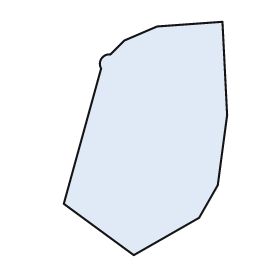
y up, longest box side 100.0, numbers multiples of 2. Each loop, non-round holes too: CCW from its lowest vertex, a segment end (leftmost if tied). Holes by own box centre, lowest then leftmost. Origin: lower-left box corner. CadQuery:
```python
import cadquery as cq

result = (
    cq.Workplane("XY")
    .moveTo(30.0, 0.0)
    .lineTo(58.0, 16.0)
    .lineTo(66.0, 30.0)
    .lineTo(70.0, 60.0)
    .lineTo(68.0, 100.0)
    .lineTo(40.0, 98.0)
    .lineTo(26.0, 92.0)
    .lineTo(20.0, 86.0)
    .threePointArc((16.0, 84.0), (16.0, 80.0))
    .lineTo(0.0, 22.0)
    .close()
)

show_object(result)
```